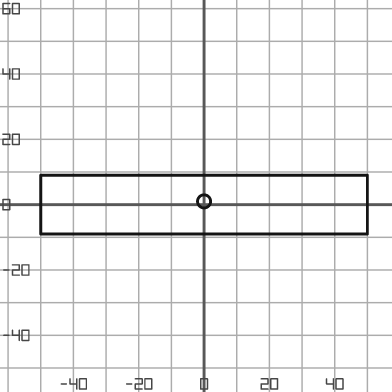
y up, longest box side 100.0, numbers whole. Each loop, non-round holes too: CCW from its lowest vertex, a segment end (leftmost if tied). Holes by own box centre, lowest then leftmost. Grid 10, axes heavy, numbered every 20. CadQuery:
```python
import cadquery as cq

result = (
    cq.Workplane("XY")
    .moveTo(-50.0, -9.0)
    .lineTo(50.0, -9.0)
    .lineTo(50.0, 9.0)
    .lineTo(-50.0, 9.0)
    .close()
    .moveTo(0.0, 1.0)
    .circle(2.0)
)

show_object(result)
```